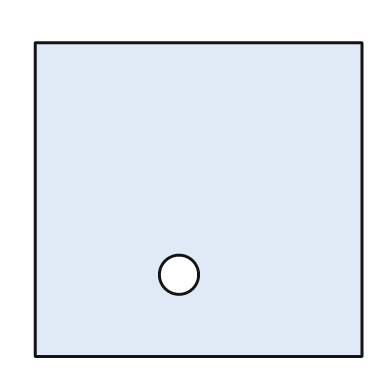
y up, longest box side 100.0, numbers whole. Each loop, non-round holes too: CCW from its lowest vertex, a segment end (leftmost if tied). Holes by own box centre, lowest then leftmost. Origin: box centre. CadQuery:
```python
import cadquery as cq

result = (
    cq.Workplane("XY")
    .moveTo(-50.0, -48.0)
    .lineTo(50.0, -48.0)
    .lineTo(50.0, 48.0)
    .lineTo(-50.0, 48.0)
    .close()
    .moveTo(-6.0, -23.0)
    .circle(6.0)
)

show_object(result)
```